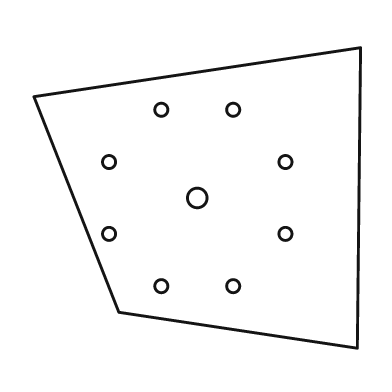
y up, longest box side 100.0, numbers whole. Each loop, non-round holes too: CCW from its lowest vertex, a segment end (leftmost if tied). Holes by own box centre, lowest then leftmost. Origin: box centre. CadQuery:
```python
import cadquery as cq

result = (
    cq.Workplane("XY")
    .moveTo(49.0, -46.0)
    .lineTo(50.0, 46.0)
    .lineTo(-50.0, 31.0)
    .lineTo(-24.0, -35.0)
    .close()
    .moveTo(-11.0, -27.0)
    .circle(2.0)
    .moveTo(11.0, -27.0)
    .circle(2.0)
    .moveTo(-27.0, -11.0)
    .circle(2.0)
    .moveTo(27.0, -11.0)
    .circle(2.0)
    .moveTo(0.0, 0.0)
    .circle(3.0)
    .moveTo(-27.0, 11.0)
    .circle(2.0)
    .moveTo(27.0, 11.0)
    .circle(2.0)
    .moveTo(-11.0, 27.0)
    .circle(2.0)
    .moveTo(11.0, 27.0)
    .circle(2.0)
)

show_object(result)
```